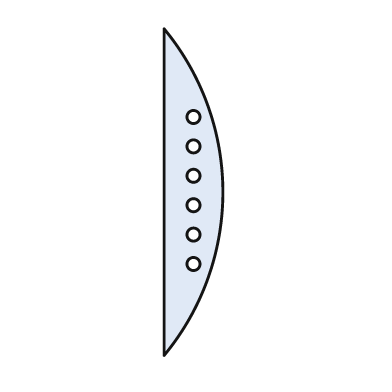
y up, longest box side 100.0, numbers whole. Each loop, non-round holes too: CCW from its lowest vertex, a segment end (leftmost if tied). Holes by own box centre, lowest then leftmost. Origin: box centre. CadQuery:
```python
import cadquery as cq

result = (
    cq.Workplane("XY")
    .moveTo(-9.0, -50.0)
    .threePointArc((9.0, 0.0), (-9.0, 50.0))
    .close()
    .moveTo(0.0, -22.0)
    .circle(2.0)
    .moveTo(0.0, -13.0)
    .circle(2.0)
    .moveTo(0.0, -4.0)
    .circle(2.0)
    .moveTo(0.0, 5.0)
    .circle(2.0)
    .moveTo(0.0, 14.0)
    .circle(2.0)
    .moveTo(0.0, 23.0)
    .circle(2.0)
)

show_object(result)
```